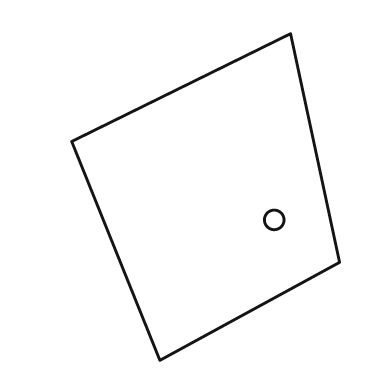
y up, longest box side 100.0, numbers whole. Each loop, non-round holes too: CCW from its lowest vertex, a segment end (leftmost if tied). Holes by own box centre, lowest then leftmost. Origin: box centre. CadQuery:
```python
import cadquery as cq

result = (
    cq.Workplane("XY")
    .moveTo(-14.0, -50.0)
    .lineTo(41.0, -20.0)
    .lineTo(26.0, 50.0)
    .lineTo(-41.0, 17.0)
    .close()
    .moveTo(21.0, -7.0)
    .circle(3.0)
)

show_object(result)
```